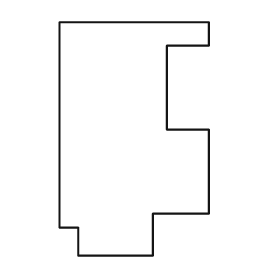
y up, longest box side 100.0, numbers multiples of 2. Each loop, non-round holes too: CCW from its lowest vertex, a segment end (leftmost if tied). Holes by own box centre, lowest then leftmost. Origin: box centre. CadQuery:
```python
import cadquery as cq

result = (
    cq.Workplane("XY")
    .moveTo(-24.0, -50.0)
    .lineTo(8.0, -50.0)
    .lineTo(8.0, -32.0)
    .lineTo(32.0, -32.0)
    .lineTo(32.0, 4.0)
    .lineTo(14.0, 4.0)
    .lineTo(14.0, 40.0)
    .lineTo(32.0, 40.0)
    .lineTo(32.0, 50.0)
    .lineTo(-32.0, 50.0)
    .lineTo(-32.0, -38.0)
    .lineTo(-24.0, -38.0)
    .close()
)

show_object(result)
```